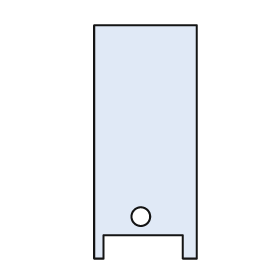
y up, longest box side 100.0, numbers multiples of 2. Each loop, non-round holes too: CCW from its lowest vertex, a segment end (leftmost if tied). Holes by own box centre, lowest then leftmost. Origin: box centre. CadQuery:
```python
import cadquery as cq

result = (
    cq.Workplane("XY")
    .moveTo(-22.0, -50.0)
    .lineTo(-18.0, -50.0)
    .lineTo(-18.0, -40.0)
    .lineTo(16.0, -40.0)
    .lineTo(16.0, -50.0)
    .lineTo(22.0, -50.0)
    .lineTo(22.0, 50.0)
    .lineTo(-22.0, 50.0)
    .close()
    .moveTo(-2.0, -32.0)
    .circle(4.0)
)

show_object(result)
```